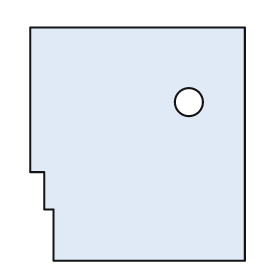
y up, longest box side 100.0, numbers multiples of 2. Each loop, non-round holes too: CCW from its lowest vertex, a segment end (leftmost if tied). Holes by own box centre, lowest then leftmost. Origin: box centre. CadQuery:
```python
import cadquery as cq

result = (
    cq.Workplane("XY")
    .moveTo(-36.0, -50.0)
    .lineTo(46.0, -50.0)
    .lineTo(46.0, 50.0)
    .lineTo(-46.0, 50.0)
    .lineTo(-46.0, -12.0)
    .lineTo(-40.0, -12.0)
    .lineTo(-40.0, -28.0)
    .lineTo(-36.0, -28.0)
    .close()
    .moveTo(22.0, 18.0)
    .circle(6.0)
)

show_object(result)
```